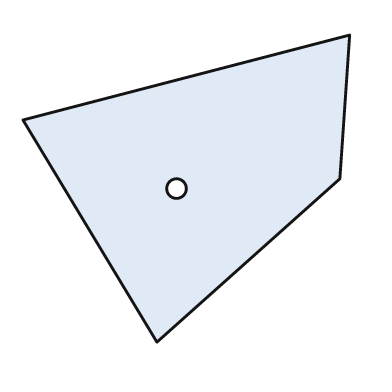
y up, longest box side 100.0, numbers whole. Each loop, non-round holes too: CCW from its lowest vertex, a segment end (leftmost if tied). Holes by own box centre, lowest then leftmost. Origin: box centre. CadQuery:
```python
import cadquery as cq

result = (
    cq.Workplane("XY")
    .moveTo(-9.0, -47.0)
    .lineTo(47.0, 3.0)
    .lineTo(50.0, 47.0)
    .lineTo(-50.0, 21.0)
    .close()
    .moveTo(-3.0, 0.0)
    .circle(3.0)
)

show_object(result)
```